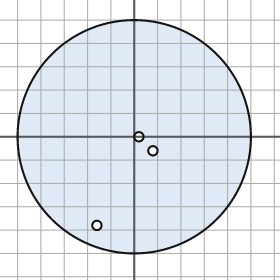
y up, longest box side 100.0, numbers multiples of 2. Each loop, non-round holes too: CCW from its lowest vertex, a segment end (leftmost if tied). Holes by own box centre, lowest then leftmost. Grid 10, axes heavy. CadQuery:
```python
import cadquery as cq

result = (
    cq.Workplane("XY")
    .moveTo(0.0, 0.0)
    .circle(50.0)
    .moveTo(-16.0, -38.0)
    .circle(2.0)
    .moveTo(8.0, -6.0)
    .circle(2.0)
    .moveTo(2.0, 0.0)
    .circle(2.0)
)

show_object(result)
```